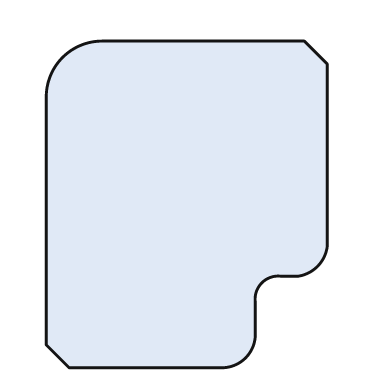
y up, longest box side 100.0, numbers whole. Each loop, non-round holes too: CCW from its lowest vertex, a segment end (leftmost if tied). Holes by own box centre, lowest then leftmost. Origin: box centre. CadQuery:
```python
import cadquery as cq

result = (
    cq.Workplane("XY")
    .moveTo(-36.0, -50.0)
    .lineTo(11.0, -50.0)
    .threePointArc((18.0, -47.0), (21.0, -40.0))
    .lineTo(21.0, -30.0)
    .threePointArc((23.0, -24.0), (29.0, -22.0))
    .lineTo(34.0, -22.0)
    .threePointArc((40.0, -19.0), (43.0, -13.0))
    .lineTo(43.0, 43.0)
    .lineTo(36.0, 50.0)
    .lineTo(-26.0, 50.0)
    .threePointArc((-38.0, 45.0), (-43.0, 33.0))
    .lineTo(-43.0, -43.0)
    .close()
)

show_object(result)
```